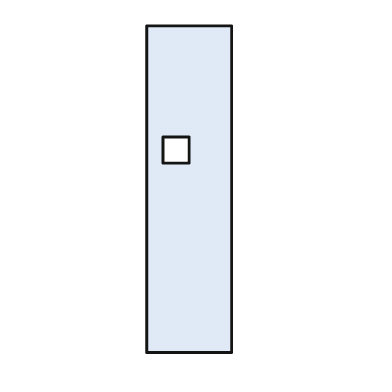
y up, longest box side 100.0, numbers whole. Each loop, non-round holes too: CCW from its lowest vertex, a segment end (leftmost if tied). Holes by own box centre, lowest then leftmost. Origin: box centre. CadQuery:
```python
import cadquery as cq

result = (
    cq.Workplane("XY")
    .moveTo(-13.0, -50.0)
    .lineTo(13.0, -50.0)
    .lineTo(13.0, 50.0)
    .lineTo(-13.0, 50.0)
    .close()
    .moveTo(-8.0, 8.0)
    .lineTo(0.0, 8.0)
    .lineTo(0.0, 16.0)
    .lineTo(-8.0, 16.0)
    .close()
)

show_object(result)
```